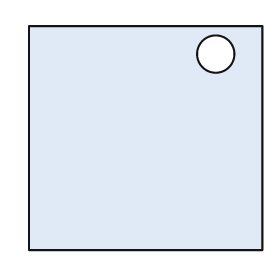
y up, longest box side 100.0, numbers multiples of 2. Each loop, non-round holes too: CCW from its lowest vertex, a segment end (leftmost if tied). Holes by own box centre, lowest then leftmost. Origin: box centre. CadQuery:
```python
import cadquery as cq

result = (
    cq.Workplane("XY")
    .moveTo(-50.0, -48.0)
    .lineTo(50.0, -48.0)
    .lineTo(50.0, 48.0)
    .lineTo(-50.0, 48.0)
    .close()
    .moveTo(30.0, 36.0)
    .circle(8.0)
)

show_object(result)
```